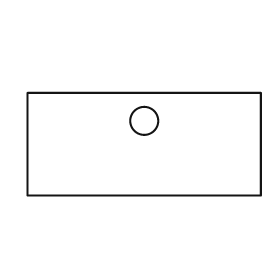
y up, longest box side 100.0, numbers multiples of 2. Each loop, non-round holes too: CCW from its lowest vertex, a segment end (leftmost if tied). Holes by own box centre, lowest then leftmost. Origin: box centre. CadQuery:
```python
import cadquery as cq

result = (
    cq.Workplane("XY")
    .moveTo(-50.0, -22.0)
    .lineTo(50.0, -22.0)
    .lineTo(50.0, 22.0)
    .lineTo(-50.0, 22.0)
    .close()
    .moveTo(0.0, 10.0)
    .circle(6.0)
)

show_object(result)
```